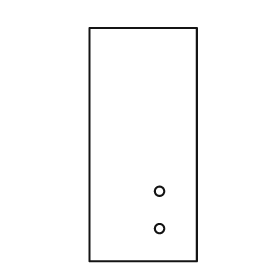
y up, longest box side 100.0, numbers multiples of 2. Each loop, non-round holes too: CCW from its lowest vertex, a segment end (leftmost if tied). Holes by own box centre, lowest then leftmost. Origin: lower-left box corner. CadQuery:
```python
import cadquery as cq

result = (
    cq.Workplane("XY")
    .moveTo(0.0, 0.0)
    .lineTo(46.0, 0.0)
    .lineTo(46.0, 100.0)
    .lineTo(0.0, 100.0)
    .close()
    .moveTo(30.0, 14.0)
    .circle(2.0)
    .moveTo(30.0, 30.0)
    .circle(2.0)
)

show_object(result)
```